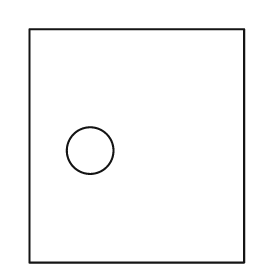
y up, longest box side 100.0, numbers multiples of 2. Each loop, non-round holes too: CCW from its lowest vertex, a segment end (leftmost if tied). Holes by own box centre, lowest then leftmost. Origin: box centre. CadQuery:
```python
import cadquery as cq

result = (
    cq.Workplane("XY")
    .moveTo(-46.0, -50.0)
    .lineTo(46.0, -50.0)
    .lineTo(46.0, 50.0)
    .lineTo(-46.0, 50.0)
    .close()
    .moveTo(-20.0, -2.0)
    .circle(10.0)
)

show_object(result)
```